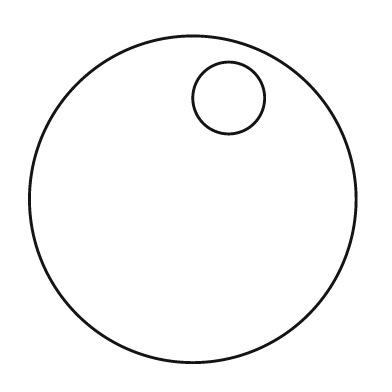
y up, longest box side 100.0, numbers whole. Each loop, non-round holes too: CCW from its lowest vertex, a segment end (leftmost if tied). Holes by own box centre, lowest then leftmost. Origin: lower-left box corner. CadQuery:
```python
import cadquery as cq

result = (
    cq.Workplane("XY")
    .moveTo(50.0, 50.0)
    .circle(50.0)
    .moveTo(61.0, 81.0)
    .circle(11.0)
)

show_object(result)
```